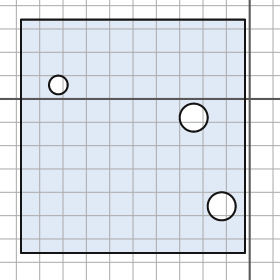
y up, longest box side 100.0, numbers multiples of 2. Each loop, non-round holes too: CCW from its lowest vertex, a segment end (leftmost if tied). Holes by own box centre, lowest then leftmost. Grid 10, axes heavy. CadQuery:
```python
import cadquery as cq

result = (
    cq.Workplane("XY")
    .moveTo(-98.0, -66.0)
    .lineTo(-2.0, -66.0)
    .lineTo(-2.0, 34.0)
    .lineTo(-98.0, 34.0)
    .close()
    .moveTo(-12.0, -46.0)
    .circle(6.0)
    .moveTo(-24.0, -8.0)
    .circle(6.0)
    .moveTo(-82.0, 6.0)
    .circle(4.0)
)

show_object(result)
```